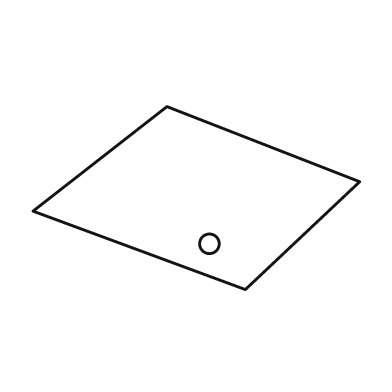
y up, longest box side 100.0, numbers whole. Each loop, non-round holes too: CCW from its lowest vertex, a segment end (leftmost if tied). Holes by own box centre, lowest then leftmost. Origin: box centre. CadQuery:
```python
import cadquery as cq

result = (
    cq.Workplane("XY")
    .moveTo(15.0, -28.0)
    .lineTo(50.0, 5.0)
    .lineTo(-9.0, 28.0)
    .lineTo(-50.0, -4.0)
    .close()
    .moveTo(4.0, -14.0)
    .circle(3.0)
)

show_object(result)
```